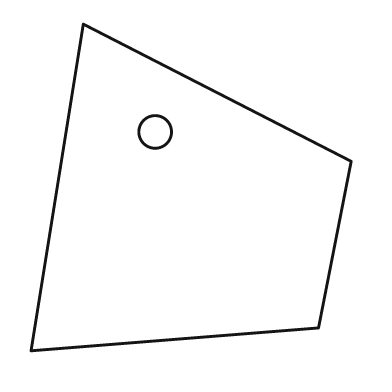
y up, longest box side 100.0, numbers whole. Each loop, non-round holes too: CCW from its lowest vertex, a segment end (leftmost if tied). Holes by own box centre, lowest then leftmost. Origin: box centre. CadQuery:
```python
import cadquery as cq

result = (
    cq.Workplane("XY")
    .moveTo(-49.0, -50.0)
    .lineTo(39.0, -43.0)
    .lineTo(49.0, 8.0)
    .lineTo(-33.0, 50.0)
    .close()
    .moveTo(-11.0, 17.0)
    .circle(5.0)
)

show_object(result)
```